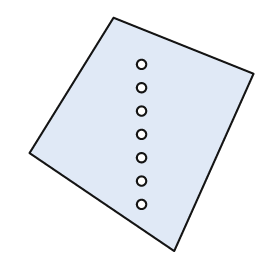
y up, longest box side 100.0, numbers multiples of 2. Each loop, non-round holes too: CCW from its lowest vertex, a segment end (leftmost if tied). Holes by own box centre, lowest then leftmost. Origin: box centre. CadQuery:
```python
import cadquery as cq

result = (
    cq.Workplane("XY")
    .moveTo(14.0, -50.0)
    .lineTo(48.0, 26.0)
    .lineTo(-12.0, 50.0)
    .lineTo(-48.0, -8.0)
    .close()
    .moveTo(0.0, -30.0)
    .circle(2.0)
    .moveTo(0.0, -20.0)
    .circle(2.0)
    .moveTo(0.0, -10.0)
    .circle(2.0)
    .moveTo(0.0, 0.0)
    .circle(2.0)
    .moveTo(0.0, 10.0)
    .circle(2.0)
    .moveTo(0.0, 20.0)
    .circle(2.0)
    .moveTo(0.0, 30.0)
    .circle(2.0)
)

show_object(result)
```